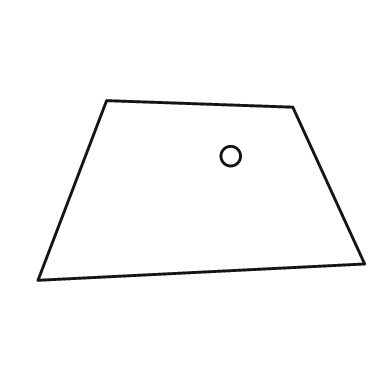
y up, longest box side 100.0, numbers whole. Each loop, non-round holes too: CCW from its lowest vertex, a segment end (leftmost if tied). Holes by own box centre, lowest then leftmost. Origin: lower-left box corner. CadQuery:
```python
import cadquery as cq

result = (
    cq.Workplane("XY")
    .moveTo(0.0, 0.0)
    .lineTo(100.0, 5.0)
    .lineTo(78.0, 53.0)
    .lineTo(21.0, 55.0)
    .close()
    .moveTo(59.0, 38.0)
    .circle(3.0)
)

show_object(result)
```